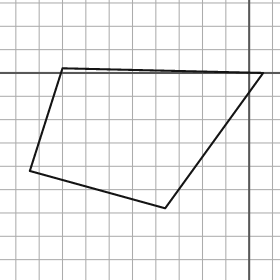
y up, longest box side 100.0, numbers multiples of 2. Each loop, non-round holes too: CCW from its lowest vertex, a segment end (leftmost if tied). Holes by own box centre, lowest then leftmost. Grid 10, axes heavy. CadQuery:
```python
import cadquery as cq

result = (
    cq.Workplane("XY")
    .moveTo(-36.0, -58.0)
    .lineTo(6.0, 0.0)
    .lineTo(-80.0, 2.0)
    .lineTo(-94.0, -42.0)
    .close()
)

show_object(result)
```